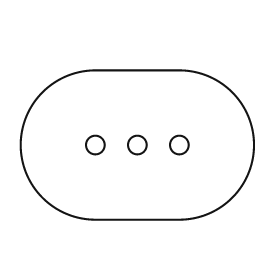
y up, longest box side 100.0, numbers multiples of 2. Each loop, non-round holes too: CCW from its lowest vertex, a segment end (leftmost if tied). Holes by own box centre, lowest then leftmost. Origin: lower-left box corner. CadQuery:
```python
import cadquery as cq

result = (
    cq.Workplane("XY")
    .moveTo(32.0, 0.0)
    .lineTo(68.0, 0.0)
    .threePointArc((100.0, 32.0), (68.0, 64.0))
    .lineTo(32.0, 64.0)
    .threePointArc((0.0, 32.0), (32.0, 0.0))
    .close()
    .moveTo(32.0, 32.0)
    .circle(4.0)
    .moveTo(50.0, 32.0)
    .circle(4.0)
    .moveTo(68.0, 32.0)
    .circle(4.0)
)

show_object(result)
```